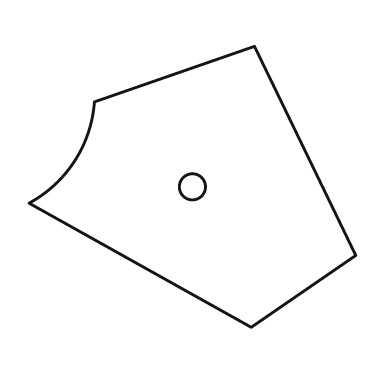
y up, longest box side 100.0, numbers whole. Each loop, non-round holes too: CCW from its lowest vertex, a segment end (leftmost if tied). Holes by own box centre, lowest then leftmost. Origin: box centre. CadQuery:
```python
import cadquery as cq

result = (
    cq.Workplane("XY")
    .moveTo(18.0, -43.0)
    .lineTo(50.0, -21.0)
    .lineTo(19.0, 43.0)
    .lineTo(-30.0, 26.0)
    .threePointArc((-36.0, 8.0), (-50.0, -5.0))
    .close()
    .moveTo(0.0, 0.0)
    .circle(4.0)
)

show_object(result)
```